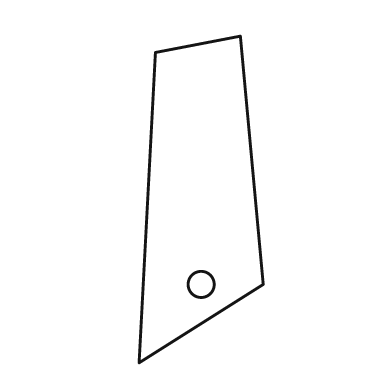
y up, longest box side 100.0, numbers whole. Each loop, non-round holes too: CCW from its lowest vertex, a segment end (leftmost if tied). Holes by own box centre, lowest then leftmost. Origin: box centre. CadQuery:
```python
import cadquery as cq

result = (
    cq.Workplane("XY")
    .moveTo(-19.0, -50.0)
    .lineTo(19.0, -26.0)
    .lineTo(12.0, 50.0)
    .lineTo(-14.0, 45.0)
    .close()
    .moveTo(0.0, -26.0)
    .circle(4.0)
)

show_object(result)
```